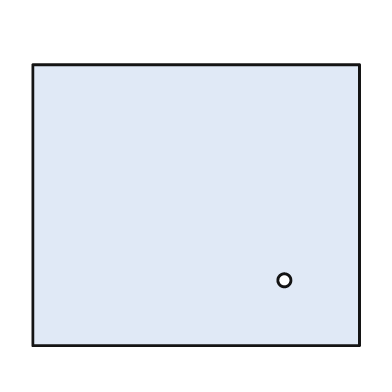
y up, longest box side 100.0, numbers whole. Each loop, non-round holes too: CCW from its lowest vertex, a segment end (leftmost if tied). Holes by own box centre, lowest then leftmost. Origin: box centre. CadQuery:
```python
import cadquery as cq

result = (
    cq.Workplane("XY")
    .moveTo(-50.0, -43.0)
    .lineTo(50.0, -43.0)
    .lineTo(50.0, 43.0)
    .lineTo(-50.0, 43.0)
    .close()
    .moveTo(27.0, -23.0)
    .circle(2.0)
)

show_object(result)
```